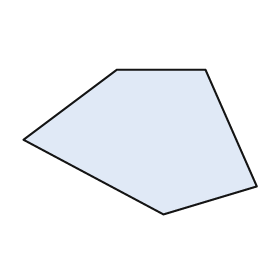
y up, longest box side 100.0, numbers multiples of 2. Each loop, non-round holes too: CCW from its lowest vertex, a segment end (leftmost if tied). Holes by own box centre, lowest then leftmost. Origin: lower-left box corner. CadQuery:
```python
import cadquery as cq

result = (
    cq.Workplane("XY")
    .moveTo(60.0, 0.0)
    .lineTo(100.0, 12.0)
    .lineTo(78.0, 62.0)
    .lineTo(40.0, 62.0)
    .lineTo(0.0, 32.0)
    .close()
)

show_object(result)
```